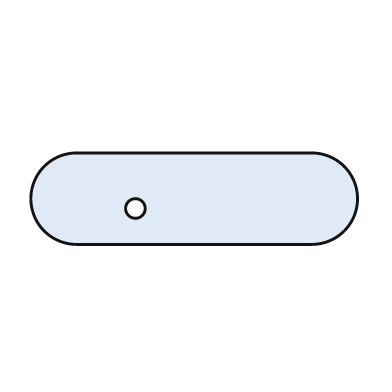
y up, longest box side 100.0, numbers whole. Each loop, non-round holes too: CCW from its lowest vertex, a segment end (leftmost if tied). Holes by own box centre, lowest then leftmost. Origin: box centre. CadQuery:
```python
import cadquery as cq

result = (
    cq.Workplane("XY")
    .moveTo(-36.0, -14.0)
    .lineTo(36.0, -14.0)
    .threePointArc((50.0, 0.0), (36.0, 14.0))
    .lineTo(-36.0, 14.0)
    .threePointArc((-50.0, 0.0), (-36.0, -14.0))
    .close()
    .moveTo(-18.0, -3.0)
    .circle(3.0)
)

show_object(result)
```